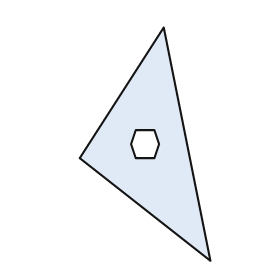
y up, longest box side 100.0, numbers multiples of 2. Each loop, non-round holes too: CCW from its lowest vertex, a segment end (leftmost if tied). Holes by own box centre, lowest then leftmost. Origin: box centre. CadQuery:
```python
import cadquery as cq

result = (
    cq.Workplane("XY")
    .moveTo(28.0, -50.0)
    .lineTo(8.0, 50.0)
    .lineTo(-28.0, -6.0)
    .close()
    .moveTo(-4.0, -6.0)
    .lineTo(4.0, -6.0)
    .lineTo(6.0, 0.0)
    .lineTo(4.0, 6.0)
    .lineTo(-4.0, 6.0)
    .lineTo(-6.0, 0.0)
    .close()
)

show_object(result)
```